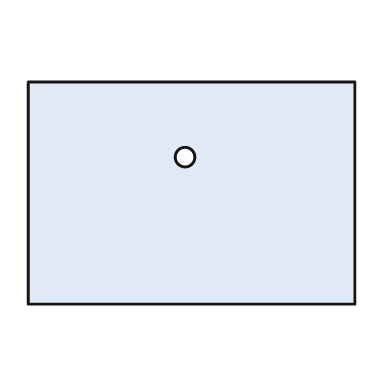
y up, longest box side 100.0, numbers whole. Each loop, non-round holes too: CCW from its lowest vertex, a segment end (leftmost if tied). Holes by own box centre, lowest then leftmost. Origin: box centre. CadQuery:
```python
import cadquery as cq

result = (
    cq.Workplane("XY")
    .moveTo(-50.0, -34.0)
    .lineTo(50.0, -34.0)
    .lineTo(50.0, 34.0)
    .lineTo(-50.0, 34.0)
    .close()
    .moveTo(-2.0, 11.0)
    .circle(3.0)
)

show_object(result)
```